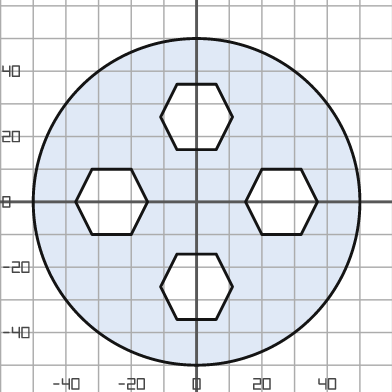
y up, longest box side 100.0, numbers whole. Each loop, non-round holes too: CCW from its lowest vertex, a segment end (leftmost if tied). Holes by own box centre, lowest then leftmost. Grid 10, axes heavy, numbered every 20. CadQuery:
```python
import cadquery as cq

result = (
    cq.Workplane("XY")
    .moveTo(0.0, 0.0)
    .circle(50.0)
    .moveTo(-6.0, -36.0)
    .lineTo(6.0, -36.0)
    .lineTo(11.0, -26.0)
    .lineTo(6.0, -16.0)
    .lineTo(-6.0, -16.0)
    .lineTo(-11.0, -26.0)
    .close()
    .moveTo(-32.0, -10.0)
    .lineTo(-20.0, -10.0)
    .lineTo(-15.0, 0.0)
    .lineTo(-20.0, 10.0)
    .lineTo(-32.0, 10.0)
    .lineTo(-37.0, 0.0)
    .close()
    .moveTo(20.0, -10.0)
    .lineTo(32.0, -10.0)
    .lineTo(37.0, 0.0)
    .lineTo(32.0, 10.0)
    .lineTo(20.0, 10.0)
    .lineTo(15.0, 0.0)
    .close()
    .moveTo(-6.0, 16.0)
    .lineTo(6.0, 16.0)
    .lineTo(11.0, 26.0)
    .lineTo(6.0, 36.0)
    .lineTo(-6.0, 36.0)
    .lineTo(-11.0, 26.0)
    .close()
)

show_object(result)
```